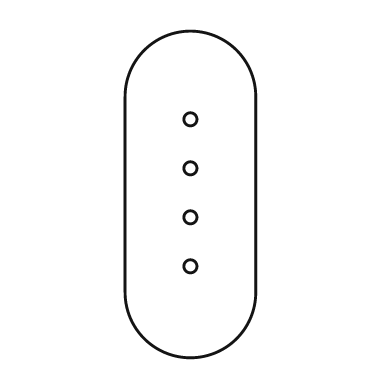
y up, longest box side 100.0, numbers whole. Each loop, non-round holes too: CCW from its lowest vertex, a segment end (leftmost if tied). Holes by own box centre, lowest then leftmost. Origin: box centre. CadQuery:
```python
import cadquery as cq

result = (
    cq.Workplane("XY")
    .moveTo(-20.0, -30.0)
    .threePointArc((0.0, -50.0), (20.0, -30.0))
    .lineTo(20.0, 30.0)
    .threePointArc((0.0, 50.0), (-20.0, 30.0))
    .close()
    .moveTo(0.0, -22.0)
    .circle(2.0)
    .moveTo(0.0, -7.0)
    .circle(2.0)
    .moveTo(0.0, 8.0)
    .circle(2.0)
    .moveTo(0.0, 23.0)
    .circle(2.0)
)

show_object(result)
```